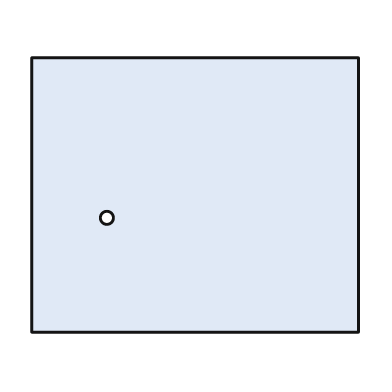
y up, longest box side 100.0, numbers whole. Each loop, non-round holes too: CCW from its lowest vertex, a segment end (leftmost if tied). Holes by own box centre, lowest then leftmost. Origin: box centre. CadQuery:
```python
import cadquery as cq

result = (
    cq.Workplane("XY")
    .moveTo(-50.0, -42.0)
    .lineTo(50.0, -42.0)
    .lineTo(50.0, 42.0)
    .lineTo(-50.0, 42.0)
    .close()
    .moveTo(-27.0, -7.0)
    .circle(2.0)
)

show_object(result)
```